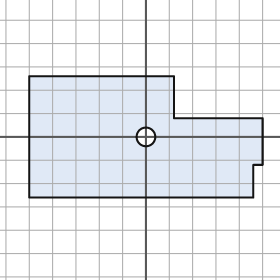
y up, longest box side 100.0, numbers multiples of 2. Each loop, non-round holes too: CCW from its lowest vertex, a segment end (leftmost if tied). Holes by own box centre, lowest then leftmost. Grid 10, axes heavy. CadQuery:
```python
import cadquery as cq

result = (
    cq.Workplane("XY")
    .moveTo(-50.0, -26.0)
    .lineTo(46.0, -26.0)
    .lineTo(46.0, -12.0)
    .lineTo(50.0, -12.0)
    .lineTo(50.0, 8.0)
    .lineTo(12.0, 8.0)
    .lineTo(12.0, 26.0)
    .lineTo(-50.0, 26.0)
    .close()
    .moveTo(0.0, 0.0)
    .circle(4.0)
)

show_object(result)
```